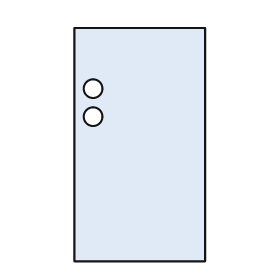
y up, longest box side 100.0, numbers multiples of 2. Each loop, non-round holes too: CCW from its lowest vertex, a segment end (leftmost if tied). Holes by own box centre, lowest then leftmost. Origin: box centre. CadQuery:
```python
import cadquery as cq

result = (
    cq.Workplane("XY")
    .moveTo(-28.0, -50.0)
    .lineTo(28.0, -50.0)
    .lineTo(28.0, 50.0)
    .lineTo(-28.0, 50.0)
    .close()
    .moveTo(-20.0, 12.0)
    .circle(4.0)
    .moveTo(-20.0, 24.0)
    .circle(4.0)
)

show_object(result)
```